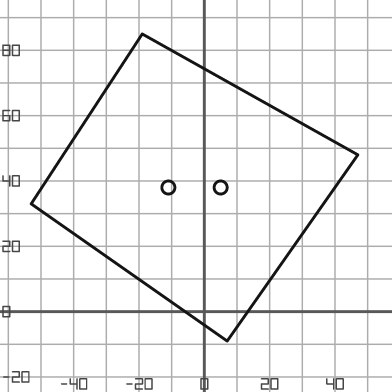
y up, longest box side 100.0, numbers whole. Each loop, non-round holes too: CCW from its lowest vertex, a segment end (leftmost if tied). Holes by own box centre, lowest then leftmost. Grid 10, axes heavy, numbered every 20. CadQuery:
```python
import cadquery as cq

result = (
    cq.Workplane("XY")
    .moveTo(7.0, -9.0)
    .lineTo(47.0, 48.0)
    .lineTo(-19.0, 85.0)
    .lineTo(-53.0, 33.0)
    .close()
    .moveTo(-11.0, 38.0)
    .circle(2.0)
    .moveTo(5.0, 38.0)
    .circle(2.0)
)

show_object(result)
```